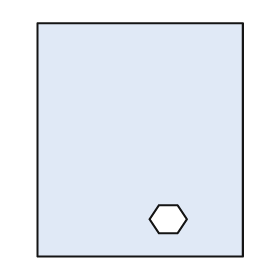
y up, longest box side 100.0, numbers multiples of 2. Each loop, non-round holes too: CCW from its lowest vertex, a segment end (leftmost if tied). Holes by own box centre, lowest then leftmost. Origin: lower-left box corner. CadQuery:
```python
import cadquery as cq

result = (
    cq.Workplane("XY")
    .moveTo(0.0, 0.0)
    .lineTo(88.0, 0.0)
    .lineTo(88.0, 100.0)
    .lineTo(0.0, 100.0)
    .close()
    .moveTo(52.0, 10.0)
    .lineTo(60.0, 10.0)
    .lineTo(64.0, 16.0)
    .lineTo(60.0, 22.0)
    .lineTo(52.0, 22.0)
    .lineTo(48.0, 16.0)
    .close()
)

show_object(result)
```